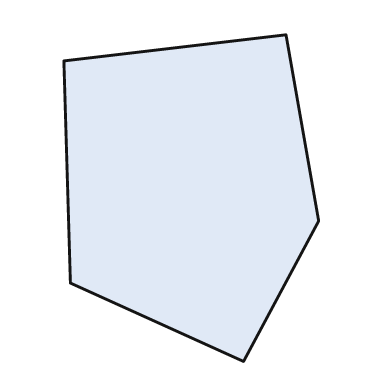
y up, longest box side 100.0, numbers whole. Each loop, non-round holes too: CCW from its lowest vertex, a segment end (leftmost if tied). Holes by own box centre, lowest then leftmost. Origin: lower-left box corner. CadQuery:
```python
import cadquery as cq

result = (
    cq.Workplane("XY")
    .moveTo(55.0, 0.0)
    .lineTo(78.0, 43.0)
    .lineTo(68.0, 100.0)
    .lineTo(0.0, 92.0)
    .lineTo(2.0, 24.0)
    .close()
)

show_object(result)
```